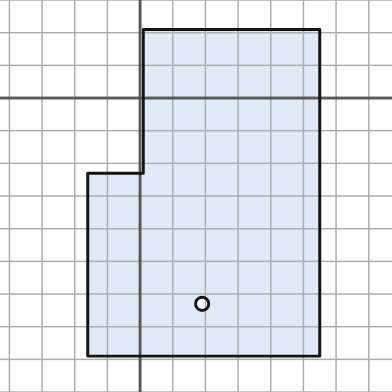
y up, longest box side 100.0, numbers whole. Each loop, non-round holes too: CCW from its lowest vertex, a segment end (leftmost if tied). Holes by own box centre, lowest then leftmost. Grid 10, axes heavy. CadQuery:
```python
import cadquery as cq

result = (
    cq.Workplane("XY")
    .moveTo(-16.0, -79.0)
    .lineTo(55.0, -79.0)
    .lineTo(55.0, 21.0)
    .lineTo(1.0, 21.0)
    .lineTo(1.0, -23.0)
    .lineTo(-16.0, -23.0)
    .close()
    .moveTo(19.0, -63.0)
    .circle(2.0)
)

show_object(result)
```